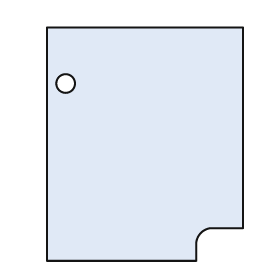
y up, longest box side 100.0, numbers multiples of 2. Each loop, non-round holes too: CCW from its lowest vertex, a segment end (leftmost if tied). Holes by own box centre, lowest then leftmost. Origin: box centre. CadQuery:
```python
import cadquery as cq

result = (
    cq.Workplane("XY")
    .moveTo(-42.0, -50.0)
    .lineTo(22.0, -50.0)
    .lineTo(22.0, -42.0)
    .threePointArc((24.0, -38.0), (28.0, -36.0))
    .lineTo(42.0, -36.0)
    .lineTo(42.0, 50.0)
    .lineTo(-42.0, 50.0)
    .close()
    .moveTo(-34.0, 26.0)
    .circle(4.0)
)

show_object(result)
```